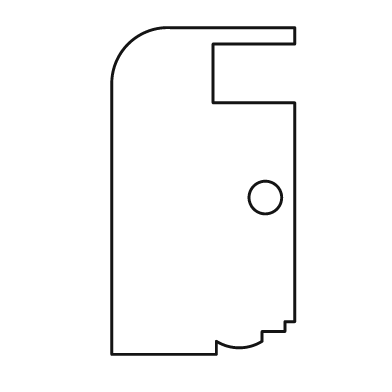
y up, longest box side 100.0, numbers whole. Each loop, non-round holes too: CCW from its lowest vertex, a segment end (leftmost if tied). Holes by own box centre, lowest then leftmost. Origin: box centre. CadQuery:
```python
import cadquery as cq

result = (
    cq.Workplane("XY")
    .moveTo(-28.0, -50.0)
    .lineTo(4.0, -50.0)
    .lineTo(4.0, -46.0)
    .threePointArc((11.0, -48.0), (18.0, -46.0))
    .lineTo(18.0, -43.0)
    .lineTo(25.0, -43.0)
    .lineTo(25.0, -40.0)
    .lineTo(28.0, -40.0)
    .lineTo(28.0, 27.0)
    .lineTo(3.0, 27.0)
    .lineTo(3.0, 45.0)
    .lineTo(28.0, 45.0)
    .lineTo(28.0, 50.0)
    .lineTo(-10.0, 50.0)
    .threePointArc((-23.0, 45.0), (-28.0, 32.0))
    .close()
    .moveTo(19.0, -2.0)
    .circle(5.0)
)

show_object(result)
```